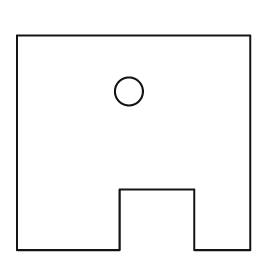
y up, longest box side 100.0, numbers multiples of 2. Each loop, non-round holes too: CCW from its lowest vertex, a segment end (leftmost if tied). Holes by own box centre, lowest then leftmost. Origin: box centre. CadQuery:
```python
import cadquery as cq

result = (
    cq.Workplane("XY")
    .moveTo(-50.0, -46.0)
    .lineTo(-6.0, -46.0)
    .lineTo(-6.0, -20.0)
    .lineTo(26.0, -20.0)
    .lineTo(26.0, -46.0)
    .lineTo(50.0, -46.0)
    .lineTo(50.0, 46.0)
    .lineTo(-50.0, 46.0)
    .close()
    .moveTo(-2.0, 22.0)
    .circle(6.0)
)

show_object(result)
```